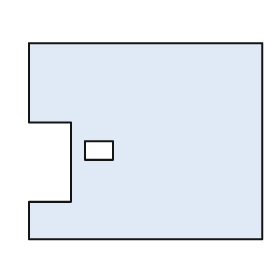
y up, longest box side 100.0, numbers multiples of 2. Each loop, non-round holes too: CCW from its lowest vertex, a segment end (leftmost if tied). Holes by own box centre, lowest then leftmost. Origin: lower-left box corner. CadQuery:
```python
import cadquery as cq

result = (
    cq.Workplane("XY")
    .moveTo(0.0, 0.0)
    .lineTo(100.0, 0.0)
    .lineTo(100.0, 84.0)
    .lineTo(0.0, 84.0)
    .lineTo(0.0, 50.0)
    .lineTo(18.0, 50.0)
    .lineTo(18.0, 16.0)
    .lineTo(0.0, 16.0)
    .close()
    .moveTo(24.0, 34.0)
    .lineTo(36.0, 34.0)
    .lineTo(36.0, 42.0)
    .lineTo(24.0, 42.0)
    .close()
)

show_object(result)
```